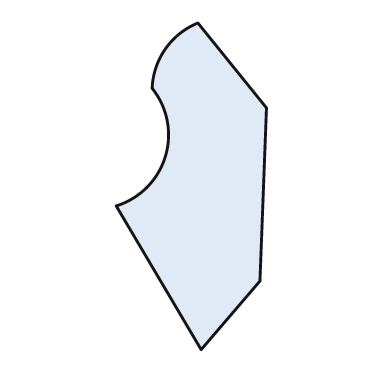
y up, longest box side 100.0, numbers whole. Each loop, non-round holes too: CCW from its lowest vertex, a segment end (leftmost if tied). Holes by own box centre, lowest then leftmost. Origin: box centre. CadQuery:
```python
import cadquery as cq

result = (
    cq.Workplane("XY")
    .moveTo(3.0, -50.0)
    .lineTo(21.0, -29.0)
    .lineTo(23.0, 24.0)
    .lineTo(2.0, 50.0)
    .threePointArc((-8.0, 42.0), (-12.0, 30.0))
    .threePointArc((-8.0, 9.0), (-23.0, -6.0))
    .close()
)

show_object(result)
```